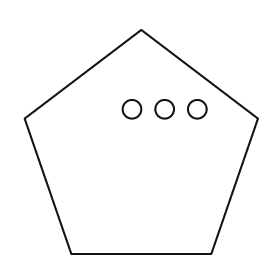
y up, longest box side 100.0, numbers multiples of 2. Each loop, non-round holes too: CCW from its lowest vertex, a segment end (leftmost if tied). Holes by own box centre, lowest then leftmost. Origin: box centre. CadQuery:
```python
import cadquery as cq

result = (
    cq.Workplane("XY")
    .moveTo(-30.0, -48.0)
    .lineTo(30.0, -48.0)
    .lineTo(50.0, 10.0)
    .lineTo(0.0, 48.0)
    .lineTo(-50.0, 10.0)
    .close()
    .moveTo(-4.0, 14.0)
    .circle(4.0)
    .moveTo(10.0, 14.0)
    .circle(4.0)
    .moveTo(24.0, 14.0)
    .circle(4.0)
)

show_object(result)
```